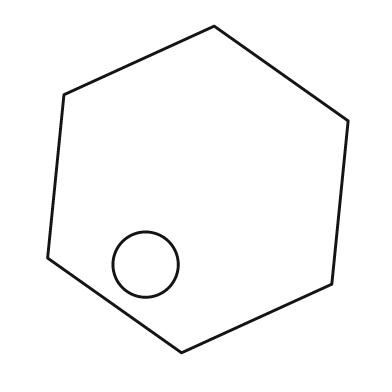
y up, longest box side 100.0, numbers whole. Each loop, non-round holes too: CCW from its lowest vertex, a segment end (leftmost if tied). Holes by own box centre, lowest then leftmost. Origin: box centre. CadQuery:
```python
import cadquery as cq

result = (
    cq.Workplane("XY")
    .moveTo(-5.0, -50.0)
    .lineTo(41.0, -29.0)
    .lineTo(46.0, 21.0)
    .lineTo(5.0, 50.0)
    .lineTo(-41.0, 29.0)
    .lineTo(-46.0, -21.0)
    .close()
    .moveTo(-16.0, -23.0)
    .circle(10.0)
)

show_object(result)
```